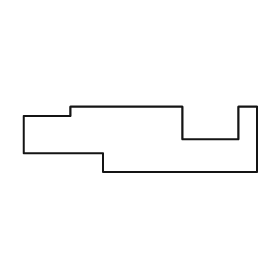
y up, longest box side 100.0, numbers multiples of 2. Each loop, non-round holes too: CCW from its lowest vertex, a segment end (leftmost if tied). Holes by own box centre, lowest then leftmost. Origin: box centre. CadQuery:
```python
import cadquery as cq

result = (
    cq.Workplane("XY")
    .moveTo(-16.0, -14.0)
    .lineTo(50.0, -14.0)
    .lineTo(50.0, 14.0)
    .lineTo(42.0, 14.0)
    .lineTo(42.0, 0.0)
    .lineTo(18.0, 0.0)
    .lineTo(18.0, 14.0)
    .lineTo(-30.0, 14.0)
    .lineTo(-30.0, 10.0)
    .lineTo(-50.0, 10.0)
    .lineTo(-50.0, -6.0)
    .lineTo(-16.0, -6.0)
    .close()
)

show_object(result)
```